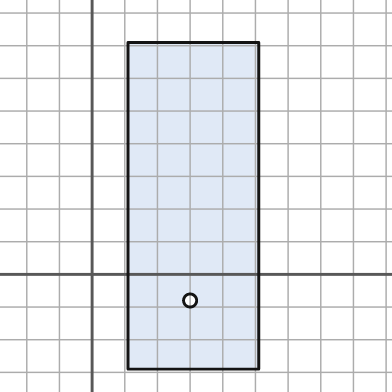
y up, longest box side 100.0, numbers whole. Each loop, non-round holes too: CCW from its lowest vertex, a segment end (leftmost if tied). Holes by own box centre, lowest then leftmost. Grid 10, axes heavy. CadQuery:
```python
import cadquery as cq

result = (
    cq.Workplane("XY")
    .moveTo(11.0, -29.0)
    .lineTo(51.0, -29.0)
    .lineTo(51.0, 71.0)
    .lineTo(11.0, 71.0)
    .close()
    .moveTo(30.0, -8.0)
    .circle(2.0)
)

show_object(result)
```